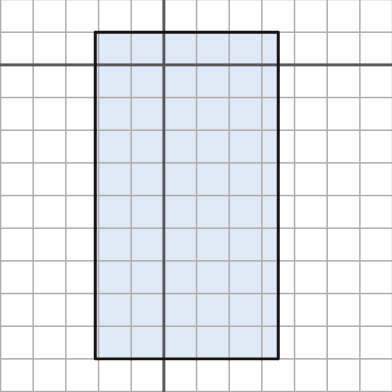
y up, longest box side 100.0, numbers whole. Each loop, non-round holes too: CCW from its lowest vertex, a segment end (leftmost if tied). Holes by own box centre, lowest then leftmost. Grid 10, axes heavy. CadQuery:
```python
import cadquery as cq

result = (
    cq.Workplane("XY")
    .moveTo(-21.0, -90.0)
    .lineTo(35.0, -90.0)
    .lineTo(35.0, 10.0)
    .lineTo(-21.0, 10.0)
    .close()
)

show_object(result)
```